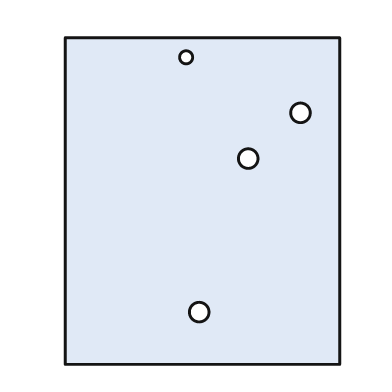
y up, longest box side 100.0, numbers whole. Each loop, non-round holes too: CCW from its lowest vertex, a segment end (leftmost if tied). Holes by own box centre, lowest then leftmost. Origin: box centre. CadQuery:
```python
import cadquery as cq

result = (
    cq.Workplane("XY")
    .moveTo(-42.0, -50.0)
    .lineTo(42.0, -50.0)
    .lineTo(42.0, 50.0)
    .lineTo(-42.0, 50.0)
    .close()
    .moveTo(-1.0, -34.0)
    .circle(3.0)
    .moveTo(14.0, 13.0)
    .circle(3.0)
    .moveTo(30.0, 27.0)
    .circle(3.0)
    .moveTo(-5.0, 44.0)
    .circle(2.0)
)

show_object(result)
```